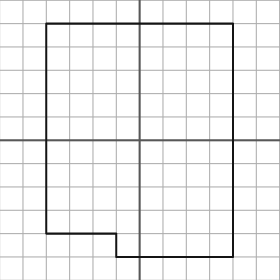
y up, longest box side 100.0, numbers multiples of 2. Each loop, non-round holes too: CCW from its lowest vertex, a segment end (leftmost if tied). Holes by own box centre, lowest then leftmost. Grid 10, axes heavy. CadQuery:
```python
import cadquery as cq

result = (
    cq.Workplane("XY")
    .moveTo(-10.0, -50.0)
    .lineTo(40.0, -50.0)
    .lineTo(40.0, 50.0)
    .lineTo(-40.0, 50.0)
    .lineTo(-40.0, -40.0)
    .lineTo(-10.0, -40.0)
    .close()
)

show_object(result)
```